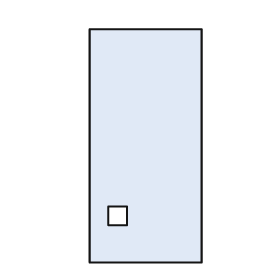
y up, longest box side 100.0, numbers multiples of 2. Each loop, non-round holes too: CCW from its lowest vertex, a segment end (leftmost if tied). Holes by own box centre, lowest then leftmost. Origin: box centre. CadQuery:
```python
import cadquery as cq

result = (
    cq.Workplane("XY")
    .moveTo(-24.0, -50.0)
    .lineTo(24.0, -50.0)
    .lineTo(24.0, 50.0)
    .lineTo(-24.0, 50.0)
    .close()
    .moveTo(-16.0, -34.0)
    .lineTo(-8.0, -34.0)
    .lineTo(-8.0, -26.0)
    .lineTo(-16.0, -26.0)
    .close()
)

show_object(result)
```